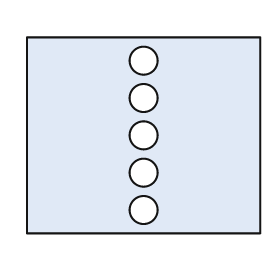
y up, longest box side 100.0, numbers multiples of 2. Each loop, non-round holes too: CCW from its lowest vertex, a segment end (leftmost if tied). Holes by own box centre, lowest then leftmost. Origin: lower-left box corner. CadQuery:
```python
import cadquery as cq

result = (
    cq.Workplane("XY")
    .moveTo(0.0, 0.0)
    .lineTo(100.0, 0.0)
    .lineTo(100.0, 84.0)
    .lineTo(0.0, 84.0)
    .close()
    .moveTo(50.0, 10.0)
    .circle(6.0)
    .moveTo(50.0, 26.0)
    .circle(6.0)
    .moveTo(50.0, 42.0)
    .circle(6.0)
    .moveTo(50.0, 58.0)
    .circle(6.0)
    .moveTo(50.0, 74.0)
    .circle(6.0)
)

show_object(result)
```